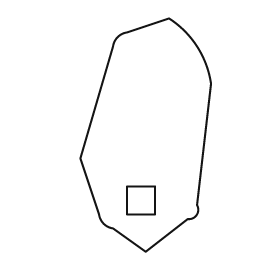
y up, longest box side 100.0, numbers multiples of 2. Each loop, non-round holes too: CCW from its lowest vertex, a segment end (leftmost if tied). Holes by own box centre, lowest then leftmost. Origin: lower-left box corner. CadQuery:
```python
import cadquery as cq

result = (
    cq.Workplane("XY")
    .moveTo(28.0, 0.0)
    .lineTo(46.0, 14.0)
    .threePointArc((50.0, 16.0), (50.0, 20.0))
    .lineTo(56.0, 72.0)
    .threePointArc((50.0, 88.0), (38.0, 100.0))
    .lineTo(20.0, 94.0)
    .threePointArc((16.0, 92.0), (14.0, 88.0))
    .lineTo(0.0, 40.0)
    .lineTo(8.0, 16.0)
    .threePointArc((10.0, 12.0), (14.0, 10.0))
    .close()
    .moveTo(20.0, 16.0)
    .lineTo(32.0, 16.0)
    .lineTo(32.0, 28.0)
    .lineTo(20.0, 28.0)
    .close()
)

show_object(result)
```